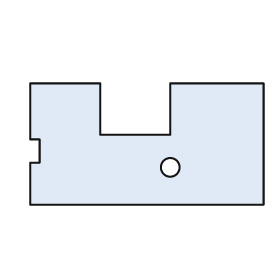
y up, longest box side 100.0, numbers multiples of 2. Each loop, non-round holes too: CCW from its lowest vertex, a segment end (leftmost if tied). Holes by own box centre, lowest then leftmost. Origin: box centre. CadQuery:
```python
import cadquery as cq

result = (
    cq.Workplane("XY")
    .moveTo(-50.0, -26.0)
    .lineTo(50.0, -26.0)
    .lineTo(50.0, 26.0)
    .lineTo(10.0, 26.0)
    .lineTo(10.0, 4.0)
    .lineTo(-20.0, 4.0)
    .lineTo(-20.0, 26.0)
    .lineTo(-50.0, 26.0)
    .lineTo(-50.0, 2.0)
    .lineTo(-46.0, 2.0)
    .lineTo(-46.0, -8.0)
    .lineTo(-50.0, -8.0)
    .close()
    .moveTo(10.0, -10.0)
    .circle(4.0)
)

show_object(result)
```